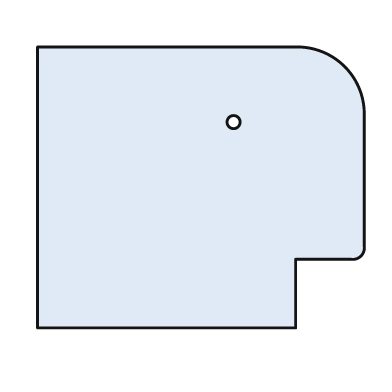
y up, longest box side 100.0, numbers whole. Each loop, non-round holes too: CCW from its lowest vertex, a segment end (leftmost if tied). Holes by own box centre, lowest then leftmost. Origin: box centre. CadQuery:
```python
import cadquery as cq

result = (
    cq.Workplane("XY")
    .moveTo(-50.0, -43.0)
    .lineTo(29.0, -43.0)
    .lineTo(29.0, -22.0)
    .lineTo(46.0, -22.0)
    .threePointArc((49.0, -21.0), (50.0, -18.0))
    .lineTo(50.0, 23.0)
    .threePointArc((44.0, 37.0), (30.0, 43.0))
    .lineTo(-50.0, 43.0)
    .close()
    .moveTo(10.0, 20.0)
    .circle(2.0)
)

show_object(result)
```